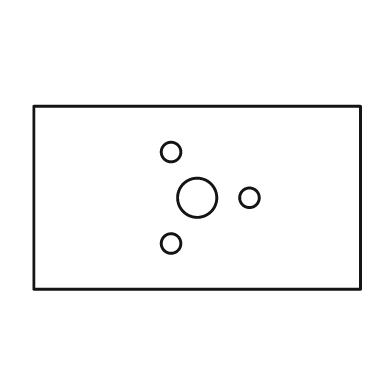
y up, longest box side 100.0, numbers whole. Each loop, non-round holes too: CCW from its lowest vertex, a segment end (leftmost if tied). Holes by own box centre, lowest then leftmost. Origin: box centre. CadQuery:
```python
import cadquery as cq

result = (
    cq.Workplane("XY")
    .moveTo(-50.0, -28.0)
    .lineTo(50.0, -28.0)
    .lineTo(50.0, 28.0)
    .lineTo(-50.0, 28.0)
    .close()
    .moveTo(-8.0, -14.0)
    .circle(3.0)
    .moveTo(0.0, 0.0)
    .circle(6.0)
    .moveTo(16.0, 0.0)
    .circle(3.0)
    .moveTo(-8.0, 14.0)
    .circle(3.0)
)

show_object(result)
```